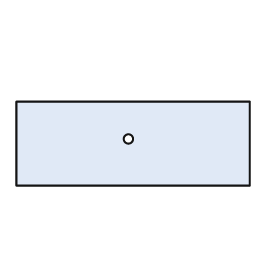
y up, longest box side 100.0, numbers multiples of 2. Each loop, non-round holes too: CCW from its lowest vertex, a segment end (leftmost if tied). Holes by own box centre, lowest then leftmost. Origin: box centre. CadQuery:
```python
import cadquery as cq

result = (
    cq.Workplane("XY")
    .moveTo(-50.0, -18.0)
    .lineTo(50.0, -18.0)
    .lineTo(50.0, 18.0)
    .lineTo(-50.0, 18.0)
    .close()
    .moveTo(-2.0, 2.0)
    .circle(2.0)
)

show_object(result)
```